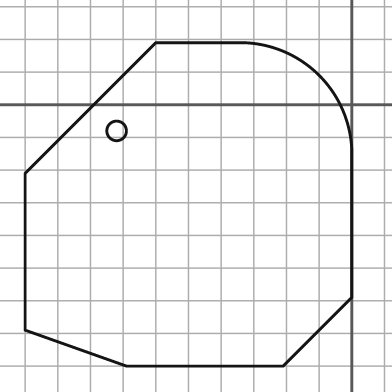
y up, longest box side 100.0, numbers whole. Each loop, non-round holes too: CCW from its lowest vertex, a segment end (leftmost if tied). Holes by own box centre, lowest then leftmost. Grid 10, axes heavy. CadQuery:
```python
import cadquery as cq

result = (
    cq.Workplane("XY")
    .moveTo(-69.0, -80.0)
    .lineTo(-21.0, -80.0)
    .lineTo(0.0, -59.0)
    .lineTo(0.0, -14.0)
    .threePointArc((-10.0, 9.0), (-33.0, 19.0))
    .lineTo(-60.0, 19.0)
    .lineTo(-100.0, -21.0)
    .lineTo(-100.0, -69.0)
    .close()
    .moveTo(-72.0, -8.0)
    .circle(3.0)
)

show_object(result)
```